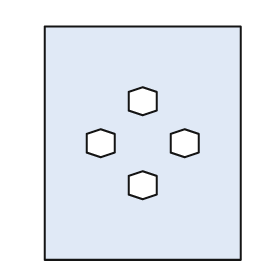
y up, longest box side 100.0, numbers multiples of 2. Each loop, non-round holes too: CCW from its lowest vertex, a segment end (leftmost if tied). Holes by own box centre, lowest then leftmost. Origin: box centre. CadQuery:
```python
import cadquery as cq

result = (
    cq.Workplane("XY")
    .moveTo(-42.0, -50.0)
    .lineTo(42.0, -50.0)
    .lineTo(42.0, 50.0)
    .lineTo(-42.0, 50.0)
    .close()
    .moveTo(0.0, -24.0)
    .lineTo(6.0, -22.0)
    .lineTo(6.0, -14.0)
    .lineTo(0.0, -12.0)
    .lineTo(-6.0, -14.0)
    .lineTo(-6.0, -22.0)
    .close()
    .moveTo(-18.0, -6.0)
    .lineTo(-12.0, -4.0)
    .lineTo(-12.0, 4.0)
    .lineTo(-18.0, 6.0)
    .lineTo(-24.0, 4.0)
    .lineTo(-24.0, -4.0)
    .close()
    .moveTo(18.0, -6.0)
    .lineTo(24.0, -4.0)
    .lineTo(24.0, 4.0)
    .lineTo(18.0, 6.0)
    .lineTo(12.0, 4.0)
    .lineTo(12.0, -4.0)
    .close()
    .moveTo(0.0, 12.0)
    .lineTo(6.0, 14.0)
    .lineTo(6.0, 22.0)
    .lineTo(0.0, 24.0)
    .lineTo(-6.0, 22.0)
    .lineTo(-6.0, 14.0)
    .close()
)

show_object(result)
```